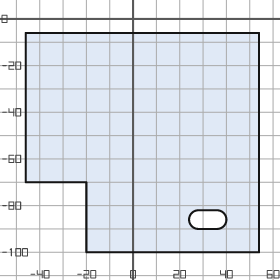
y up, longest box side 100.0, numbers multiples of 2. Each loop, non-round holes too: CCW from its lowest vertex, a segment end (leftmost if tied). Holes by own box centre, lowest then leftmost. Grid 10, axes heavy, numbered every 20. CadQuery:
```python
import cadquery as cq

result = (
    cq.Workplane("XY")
    .moveTo(-20.0, -100.0)
    .lineTo(54.0, -100.0)
    .lineTo(54.0, -6.0)
    .lineTo(-46.0, -6.0)
    .lineTo(-46.0, -70.0)
    .lineTo(-20.0, -70.0)
    .close()
    .moveTo(28.0, -90.0)
    .lineTo(36.0, -90.0)
    .threePointArc((40.0, -86.0), (36.0, -82.0))
    .lineTo(28.0, -82.0)
    .threePointArc((24.0, -86.0), (28.0, -90.0))
    .close()
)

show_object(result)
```